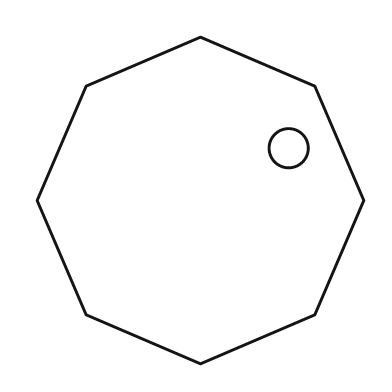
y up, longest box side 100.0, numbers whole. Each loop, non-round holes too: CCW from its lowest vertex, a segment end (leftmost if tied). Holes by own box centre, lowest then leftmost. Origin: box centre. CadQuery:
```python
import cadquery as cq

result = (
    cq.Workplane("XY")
    .moveTo(0.0, -50.0)
    .lineTo(35.0, -35.0)
    .lineTo(50.0, 0.0)
    .lineTo(35.0, 35.0)
    .lineTo(0.0, 50.0)
    .lineTo(-35.0, 35.0)
    .lineTo(-50.0, 0.0)
    .lineTo(-35.0, -35.0)
    .close()
    .moveTo(27.0, 16.0)
    .circle(6.0)
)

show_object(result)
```